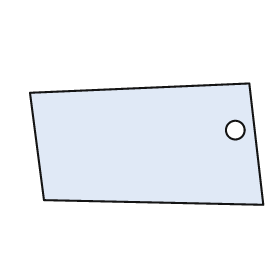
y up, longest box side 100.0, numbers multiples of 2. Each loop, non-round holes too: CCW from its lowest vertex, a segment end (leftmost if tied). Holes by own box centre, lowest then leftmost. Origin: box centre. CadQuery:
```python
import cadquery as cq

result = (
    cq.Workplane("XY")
    .moveTo(50.0, -26.0)
    .lineTo(44.0, 26.0)
    .lineTo(-50.0, 22.0)
    .lineTo(-44.0, -24.0)
    .close()
    .moveTo(38.0, 6.0)
    .circle(4.0)
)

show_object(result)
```